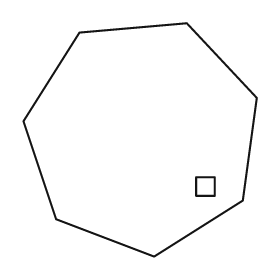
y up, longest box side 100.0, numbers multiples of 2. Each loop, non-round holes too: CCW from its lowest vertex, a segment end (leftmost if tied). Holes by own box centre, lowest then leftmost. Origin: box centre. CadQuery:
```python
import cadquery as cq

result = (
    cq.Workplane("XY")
    .moveTo(6.0, -50.0)
    .lineTo(44.0, -26.0)
    .lineTo(50.0, 18.0)
    .lineTo(20.0, 50.0)
    .lineTo(-26.0, 46.0)
    .lineTo(-50.0, 8.0)
    .lineTo(-36.0, -34.0)
    .close()
    .moveTo(24.0, -24.0)
    .lineTo(32.0, -24.0)
    .lineTo(32.0, -16.0)
    .lineTo(24.0, -16.0)
    .close()
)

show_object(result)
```